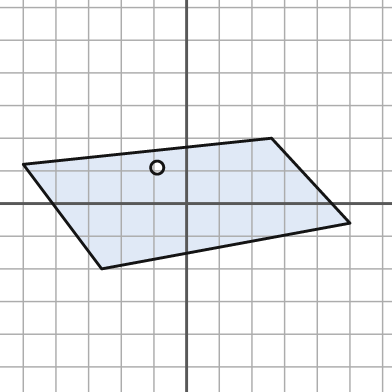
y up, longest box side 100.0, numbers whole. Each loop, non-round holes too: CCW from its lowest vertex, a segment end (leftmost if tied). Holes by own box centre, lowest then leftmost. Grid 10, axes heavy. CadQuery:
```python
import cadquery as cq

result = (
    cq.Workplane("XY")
    .moveTo(-26.0, -20.0)
    .lineTo(50.0, -6.0)
    .lineTo(26.0, 20.0)
    .lineTo(-50.0, 12.0)
    .close()
    .moveTo(-9.0, 11.0)
    .circle(2.0)
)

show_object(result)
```